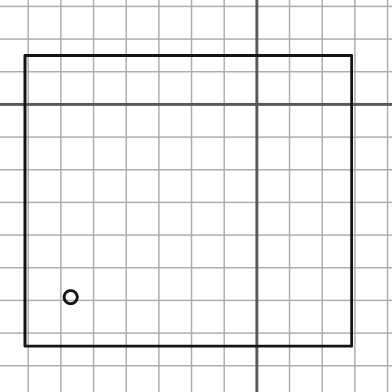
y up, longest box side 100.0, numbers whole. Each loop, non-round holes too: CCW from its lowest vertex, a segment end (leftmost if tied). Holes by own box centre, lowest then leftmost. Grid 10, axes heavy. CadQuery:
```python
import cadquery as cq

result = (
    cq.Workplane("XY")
    .moveTo(-71.0, -74.0)
    .lineTo(29.0, -74.0)
    .lineTo(29.0, 15.0)
    .lineTo(-71.0, 15.0)
    .close()
    .moveTo(-57.0, -59.0)
    .circle(2.0)
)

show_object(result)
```